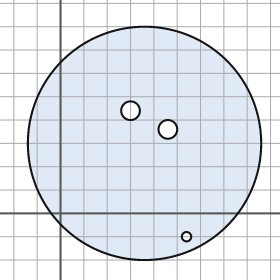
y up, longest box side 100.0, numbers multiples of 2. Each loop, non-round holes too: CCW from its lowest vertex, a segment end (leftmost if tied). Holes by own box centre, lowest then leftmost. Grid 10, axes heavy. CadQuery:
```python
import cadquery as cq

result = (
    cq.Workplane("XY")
    .moveTo(36.0, 30.0)
    .circle(50.0)
    .moveTo(54.0, -10.0)
    .circle(2.0)
    .moveTo(46.0, 36.0)
    .circle(4.0)
    .moveTo(30.0, 44.0)
    .circle(4.0)
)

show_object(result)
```